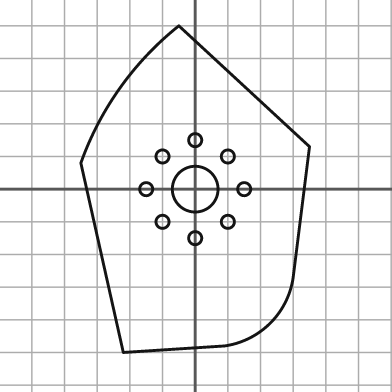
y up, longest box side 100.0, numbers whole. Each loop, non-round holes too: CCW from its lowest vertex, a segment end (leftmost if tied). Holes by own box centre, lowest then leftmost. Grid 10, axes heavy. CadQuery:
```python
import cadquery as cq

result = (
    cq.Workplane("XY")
    .moveTo(-22.0, -50.0)
    .lineTo(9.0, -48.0)
    .threePointArc((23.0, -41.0), (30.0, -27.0))
    .lineTo(35.0, 13.0)
    .lineTo(-5.0, 50.0)
    .threePointArc((-23.0, 31.0), (-35.0, 8.0))
    .close()
    .moveTo(0.0, -15.0)
    .circle(2.0)
    .moveTo(-10.0, -10.0)
    .circle(2.0)
    .moveTo(10.0, -10.0)
    .circle(2.0)
    .moveTo(-15.0, 0.0)
    .circle(2.0)
    .moveTo(0.0, 0.0)
    .circle(7.0)
    .moveTo(15.0, 0.0)
    .circle(2.0)
    .moveTo(-10.0, 10.0)
    .circle(2.0)
    .moveTo(10.0, 10.0)
    .circle(2.0)
    .moveTo(0.0, 15.0)
    .circle(2.0)
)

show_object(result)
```